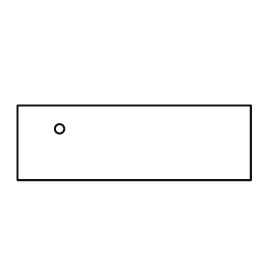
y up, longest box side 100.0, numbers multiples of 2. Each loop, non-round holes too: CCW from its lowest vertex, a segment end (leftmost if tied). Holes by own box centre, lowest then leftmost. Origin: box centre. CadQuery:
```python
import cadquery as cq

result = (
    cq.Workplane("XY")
    .moveTo(-50.0, -16.0)
    .lineTo(50.0, -16.0)
    .lineTo(50.0, 16.0)
    .lineTo(-50.0, 16.0)
    .close()
    .moveTo(-32.0, 6.0)
    .circle(2.0)
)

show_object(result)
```